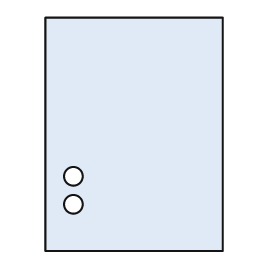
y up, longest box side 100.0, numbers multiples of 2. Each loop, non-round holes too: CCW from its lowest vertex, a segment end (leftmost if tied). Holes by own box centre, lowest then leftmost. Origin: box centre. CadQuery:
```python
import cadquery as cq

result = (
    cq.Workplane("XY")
    .moveTo(-38.0, -50.0)
    .lineTo(38.0, -50.0)
    .lineTo(38.0, 50.0)
    .lineTo(-38.0, 50.0)
    .close()
    .moveTo(-26.0, -30.0)
    .circle(4.0)
    .moveTo(-26.0, -18.0)
    .circle(4.0)
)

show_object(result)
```